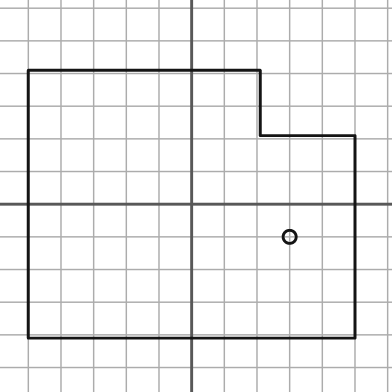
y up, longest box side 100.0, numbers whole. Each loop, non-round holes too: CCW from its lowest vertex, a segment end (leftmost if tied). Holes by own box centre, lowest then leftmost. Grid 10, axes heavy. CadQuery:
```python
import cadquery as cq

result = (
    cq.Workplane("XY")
    .moveTo(-50.0, -41.0)
    .lineTo(50.0, -41.0)
    .lineTo(50.0, 21.0)
    .lineTo(21.0, 21.0)
    .lineTo(21.0, 41.0)
    .lineTo(-50.0, 41.0)
    .close()
    .moveTo(30.0, -10.0)
    .circle(2.0)
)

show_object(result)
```